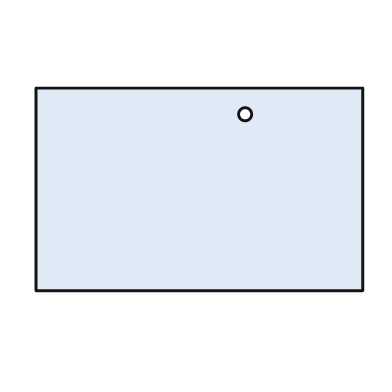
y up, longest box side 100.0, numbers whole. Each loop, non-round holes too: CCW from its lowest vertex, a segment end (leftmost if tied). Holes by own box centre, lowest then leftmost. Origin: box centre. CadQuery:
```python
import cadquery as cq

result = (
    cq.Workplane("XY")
    .moveTo(-50.0, -31.0)
    .lineTo(50.0, -31.0)
    .lineTo(50.0, 31.0)
    .lineTo(-50.0, 31.0)
    .close()
    .moveTo(14.0, 23.0)
    .circle(2.0)
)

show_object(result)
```